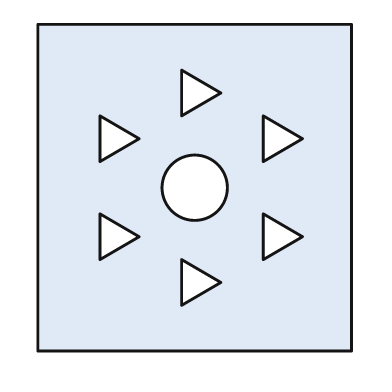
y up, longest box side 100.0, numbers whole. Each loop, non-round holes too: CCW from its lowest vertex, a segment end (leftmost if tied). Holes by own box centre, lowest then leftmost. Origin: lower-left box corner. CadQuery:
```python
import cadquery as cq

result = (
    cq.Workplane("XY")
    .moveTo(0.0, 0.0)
    .lineTo(96.0, 0.0)
    .lineTo(96.0, 100.0)
    .lineTo(0.0, 100.0)
    .close()
    .moveTo(44.0, 14.0)
    .lineTo(56.0, 21.0)
    .lineTo(44.0, 28.0)
    .close()
    .moveTo(19.0, 28.0)
    .lineTo(31.0, 35.0)
    .lineTo(19.0, 42.0)
    .close()
    .moveTo(69.0, 28.0)
    .lineTo(81.0, 35.0)
    .lineTo(69.0, 42.0)
    .close()
    .moveTo(48.0, 50.0)
    .circle(10.0)
    .moveTo(19.0, 58.0)
    .lineTo(31.0, 65.0)
    .lineTo(19.0, 72.0)
    .close()
    .moveTo(69.0, 58.0)
    .lineTo(81.0, 65.0)
    .lineTo(69.0, 72.0)
    .close()
    .moveTo(44.0, 72.0)
    .lineTo(56.0, 79.0)
    .lineTo(44.0, 86.0)
    .close()
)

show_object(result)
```